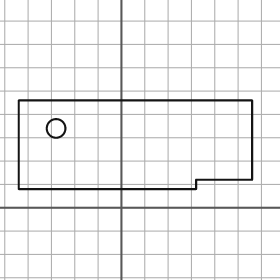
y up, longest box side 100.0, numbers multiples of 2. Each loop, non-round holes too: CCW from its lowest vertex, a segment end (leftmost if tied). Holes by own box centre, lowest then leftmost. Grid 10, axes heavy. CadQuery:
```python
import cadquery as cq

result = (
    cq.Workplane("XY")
    .moveTo(-44.0, 8.0)
    .lineTo(32.0, 8.0)
    .lineTo(32.0, 12.0)
    .lineTo(56.0, 12.0)
    .lineTo(56.0, 46.0)
    .lineTo(-44.0, 46.0)
    .close()
    .moveTo(-28.0, 34.0)
    .circle(4.0)
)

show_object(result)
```